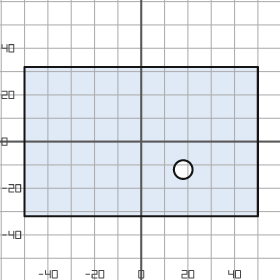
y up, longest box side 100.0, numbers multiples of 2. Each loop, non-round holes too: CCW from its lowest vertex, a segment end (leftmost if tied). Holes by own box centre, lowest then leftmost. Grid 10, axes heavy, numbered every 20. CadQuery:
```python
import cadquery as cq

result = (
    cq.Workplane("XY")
    .moveTo(-50.0, -32.0)
    .lineTo(50.0, -32.0)
    .lineTo(50.0, 32.0)
    .lineTo(-50.0, 32.0)
    .close()
    .moveTo(18.0, -12.0)
    .circle(4.0)
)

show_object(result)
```